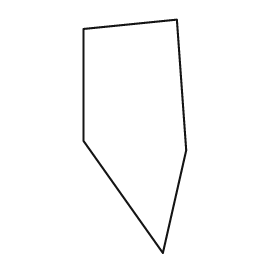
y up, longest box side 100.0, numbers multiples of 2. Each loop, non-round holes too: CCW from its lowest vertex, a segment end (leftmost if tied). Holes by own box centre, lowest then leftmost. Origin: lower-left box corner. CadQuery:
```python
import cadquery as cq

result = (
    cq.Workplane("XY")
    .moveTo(34.0, 0.0)
    .lineTo(44.0, 44.0)
    .lineTo(40.0, 100.0)
    .lineTo(0.0, 96.0)
    .lineTo(0.0, 48.0)
    .close()
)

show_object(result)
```